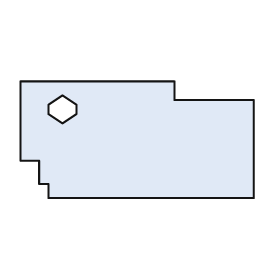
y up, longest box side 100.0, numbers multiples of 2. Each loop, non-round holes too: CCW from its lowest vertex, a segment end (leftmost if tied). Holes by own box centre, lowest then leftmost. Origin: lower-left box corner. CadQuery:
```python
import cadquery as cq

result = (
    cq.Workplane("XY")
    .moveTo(12.0, 0.0)
    .lineTo(100.0, 0.0)
    .lineTo(100.0, 42.0)
    .lineTo(66.0, 42.0)
    .lineTo(66.0, 50.0)
    .lineTo(0.0, 50.0)
    .lineTo(0.0, 16.0)
    .lineTo(8.0, 16.0)
    .lineTo(8.0, 6.0)
    .lineTo(12.0, 6.0)
    .close()
    .moveTo(18.0, 32.0)
    .lineTo(24.0, 36.0)
    .lineTo(24.0, 40.0)
    .lineTo(18.0, 44.0)
    .lineTo(12.0, 40.0)
    .lineTo(12.0, 36.0)
    .close()
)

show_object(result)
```